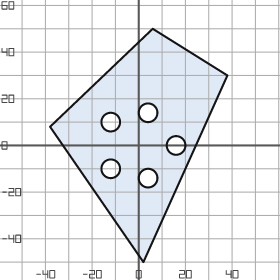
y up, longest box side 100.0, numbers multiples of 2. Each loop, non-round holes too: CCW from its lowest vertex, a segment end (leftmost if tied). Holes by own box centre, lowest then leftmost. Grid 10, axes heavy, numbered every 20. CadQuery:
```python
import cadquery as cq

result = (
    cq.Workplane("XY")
    .moveTo(2.0, -50.0)
    .lineTo(38.0, 30.0)
    .lineTo(6.0, 50.0)
    .lineTo(-38.0, 8.0)
    .close()
    .moveTo(4.0, -14.0)
    .circle(4.0)
    .moveTo(-12.0, -10.0)
    .circle(4.0)
    .moveTo(16.0, 0.0)
    .circle(4.0)
    .moveTo(-12.0, 10.0)
    .circle(4.0)
    .moveTo(4.0, 14.0)
    .circle(4.0)
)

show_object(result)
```